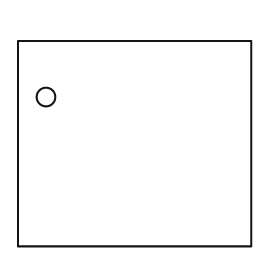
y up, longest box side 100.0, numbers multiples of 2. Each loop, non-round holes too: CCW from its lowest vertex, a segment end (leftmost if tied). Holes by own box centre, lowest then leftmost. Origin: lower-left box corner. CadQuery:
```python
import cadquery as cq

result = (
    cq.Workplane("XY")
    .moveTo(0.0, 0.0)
    .lineTo(100.0, 0.0)
    .lineTo(100.0, 88.0)
    .lineTo(0.0, 88.0)
    .close()
    .moveTo(12.0, 64.0)
    .circle(4.0)
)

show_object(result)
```